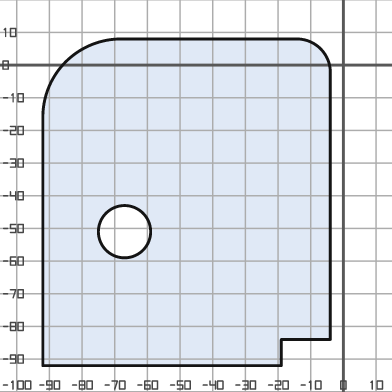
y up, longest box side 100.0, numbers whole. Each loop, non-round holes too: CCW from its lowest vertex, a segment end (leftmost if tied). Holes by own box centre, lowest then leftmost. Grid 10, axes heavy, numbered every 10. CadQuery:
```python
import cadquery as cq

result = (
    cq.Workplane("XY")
    .moveTo(-92.0, -92.0)
    .lineTo(-19.0, -92.0)
    .lineTo(-19.0, -84.0)
    .lineTo(-4.0, -84.0)
    .lineTo(-4.0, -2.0)
    .threePointArc((-7.0, 5.0), (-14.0, 8.0))
    .lineTo(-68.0, 8.0)
    .threePointArc((-85.0, 1.0), (-92.0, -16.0))
    .close()
    .moveTo(-67.0, -51.0)
    .circle(8.0)
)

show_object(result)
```